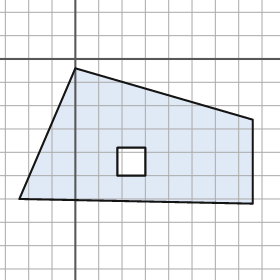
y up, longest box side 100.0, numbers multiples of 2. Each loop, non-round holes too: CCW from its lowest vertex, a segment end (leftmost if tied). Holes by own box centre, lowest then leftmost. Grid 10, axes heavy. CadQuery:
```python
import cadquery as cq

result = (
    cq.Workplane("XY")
    .moveTo(76.0, -62.0)
    .lineTo(76.0, -26.0)
    .lineTo(0.0, -4.0)
    .lineTo(-24.0, -60.0)
    .close()
    .moveTo(18.0, -50.0)
    .lineTo(30.0, -50.0)
    .lineTo(30.0, -38.0)
    .lineTo(18.0, -38.0)
    .close()
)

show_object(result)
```